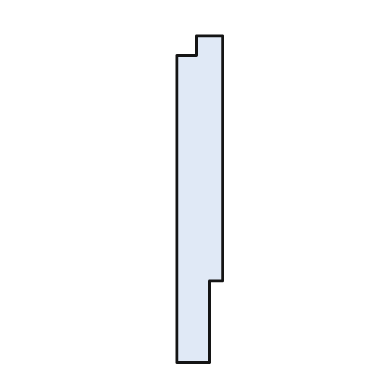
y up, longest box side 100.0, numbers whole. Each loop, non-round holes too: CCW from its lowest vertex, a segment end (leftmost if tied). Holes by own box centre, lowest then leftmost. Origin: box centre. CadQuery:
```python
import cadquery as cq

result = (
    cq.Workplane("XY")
    .moveTo(-7.0, -50.0)
    .lineTo(3.0, -50.0)
    .lineTo(3.0, -25.0)
    .lineTo(7.0, -25.0)
    .lineTo(7.0, 50.0)
    .lineTo(-1.0, 50.0)
    .lineTo(-1.0, 44.0)
    .lineTo(-7.0, 44.0)
    .close()
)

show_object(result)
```